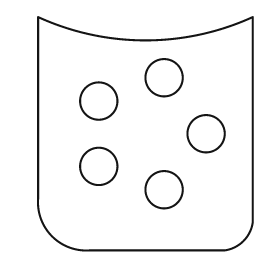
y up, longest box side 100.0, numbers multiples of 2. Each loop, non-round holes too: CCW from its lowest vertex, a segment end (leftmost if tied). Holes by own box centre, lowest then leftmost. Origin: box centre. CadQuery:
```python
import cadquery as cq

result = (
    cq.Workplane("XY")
    .moveTo(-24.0, -50.0)
    .lineTo(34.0, -50.0)
    .threePointArc((42.0, -46.0), (46.0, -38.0))
    .lineTo(46.0, 50.0)
    .threePointArc((0.0, 40.0), (-46.0, 50.0))
    .lineTo(-46.0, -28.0)
    .threePointArc((-40.0, -44.0), (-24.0, -50.0))
    .close()
    .moveTo(8.0, -24.0)
    .circle(8.0)
    .moveTo(-20.0, -14.0)
    .circle(8.0)
    .moveTo(26.0, 0.0)
    .circle(8.0)
    .moveTo(-20.0, 14.0)
    .circle(8.0)
    .moveTo(8.0, 24.0)
    .circle(8.0)
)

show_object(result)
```